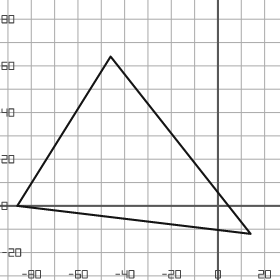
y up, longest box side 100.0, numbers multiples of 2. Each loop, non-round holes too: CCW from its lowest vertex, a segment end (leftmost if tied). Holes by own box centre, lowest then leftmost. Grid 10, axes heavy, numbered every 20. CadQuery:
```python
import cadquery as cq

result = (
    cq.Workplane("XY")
    .moveTo(14.0, -12.0)
    .lineTo(-46.0, 64.0)
    .lineTo(-86.0, 0.0)
    .close()
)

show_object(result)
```